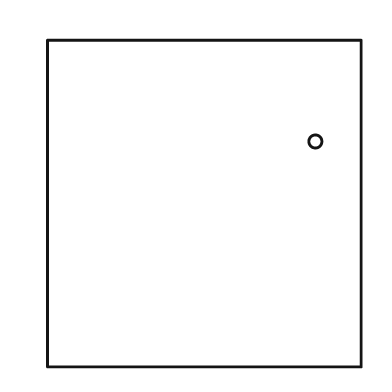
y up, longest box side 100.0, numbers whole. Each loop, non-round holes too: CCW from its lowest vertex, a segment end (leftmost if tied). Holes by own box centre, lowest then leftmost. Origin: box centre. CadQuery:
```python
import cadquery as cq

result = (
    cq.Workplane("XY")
    .moveTo(-48.0, -50.0)
    .lineTo(48.0, -50.0)
    .lineTo(48.0, 50.0)
    .lineTo(-48.0, 50.0)
    .close()
    .moveTo(34.0, 19.0)
    .circle(2.0)
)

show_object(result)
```